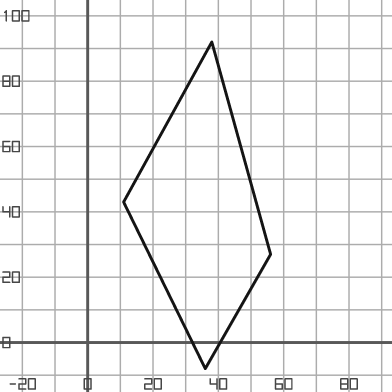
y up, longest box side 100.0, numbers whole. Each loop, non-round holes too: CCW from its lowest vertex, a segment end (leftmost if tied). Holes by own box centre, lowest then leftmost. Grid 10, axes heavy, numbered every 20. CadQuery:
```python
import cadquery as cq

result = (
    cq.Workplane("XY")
    .moveTo(36.0, -8.0)
    .lineTo(56.0, 27.0)
    .lineTo(38.0, 92.0)
    .lineTo(11.0, 43.0)
    .close()
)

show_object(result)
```